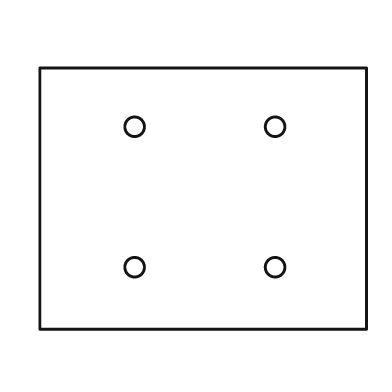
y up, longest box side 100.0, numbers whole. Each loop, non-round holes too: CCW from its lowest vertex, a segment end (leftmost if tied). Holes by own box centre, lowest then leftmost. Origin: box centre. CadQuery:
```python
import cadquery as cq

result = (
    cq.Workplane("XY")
    .moveTo(-50.0, -40.0)
    .lineTo(50.0, -40.0)
    .lineTo(50.0, 40.0)
    .lineTo(-50.0, 40.0)
    .close()
    .moveTo(-21.0, -21.0)
    .circle(3.0)
    .moveTo(22.0, -21.0)
    .circle(3.0)
    .moveTo(-21.0, 22.0)
    .circle(3.0)
    .moveTo(22.0, 22.0)
    .circle(3.0)
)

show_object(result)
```